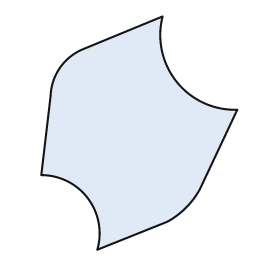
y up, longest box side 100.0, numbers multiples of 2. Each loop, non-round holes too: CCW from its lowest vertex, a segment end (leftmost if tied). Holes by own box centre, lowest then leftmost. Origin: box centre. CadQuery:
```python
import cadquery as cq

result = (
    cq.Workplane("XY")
    .moveTo(-18.0, -50.0)
    .lineTo(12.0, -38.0)
    .threePointArc((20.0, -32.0), (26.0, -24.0))
    .lineTo(42.0, 10.0)
    .threePointArc((16.0, 22.0), (10.0, 50.0))
    .lineTo(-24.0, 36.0)
    .threePointArc((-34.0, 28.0), (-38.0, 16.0))
    .lineTo(-42.0, -18.0)
    .threePointArc((-22.0, -28.0), (-18.0, -50.0))
    .close()
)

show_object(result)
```